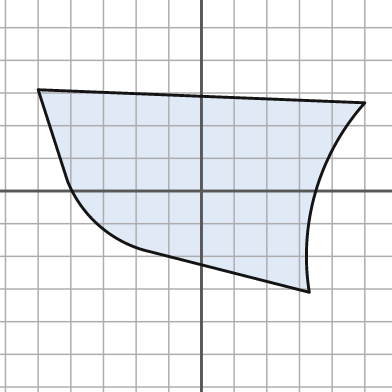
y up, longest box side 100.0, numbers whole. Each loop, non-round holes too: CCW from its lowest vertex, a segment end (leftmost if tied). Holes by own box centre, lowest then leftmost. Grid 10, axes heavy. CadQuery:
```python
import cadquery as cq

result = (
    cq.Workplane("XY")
    .moveTo(33.0, -31.0)
    .threePointArc((35.0, 0.0), (50.0, 27.0))
    .lineTo(-50.0, 31.0)
    .lineTo(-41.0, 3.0)
    .threePointArc((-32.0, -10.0), (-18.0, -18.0))
    .close()
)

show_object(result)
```